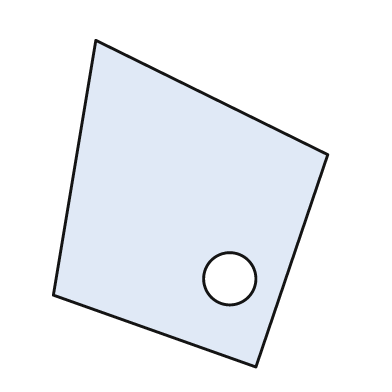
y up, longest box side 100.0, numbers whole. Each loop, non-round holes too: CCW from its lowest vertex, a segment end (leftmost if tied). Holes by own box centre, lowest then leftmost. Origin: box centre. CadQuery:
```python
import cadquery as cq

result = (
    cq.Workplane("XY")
    .moveTo(20.0, -50.0)
    .lineTo(42.0, 15.0)
    .lineTo(-29.0, 50.0)
    .lineTo(-42.0, -28.0)
    .close()
    .moveTo(12.0, -23.0)
    .circle(8.0)
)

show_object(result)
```